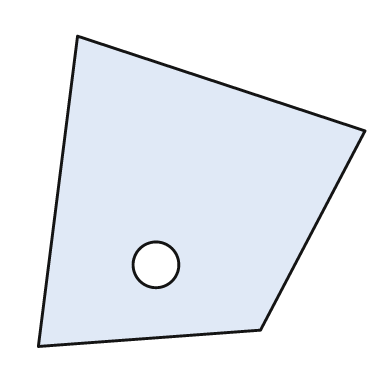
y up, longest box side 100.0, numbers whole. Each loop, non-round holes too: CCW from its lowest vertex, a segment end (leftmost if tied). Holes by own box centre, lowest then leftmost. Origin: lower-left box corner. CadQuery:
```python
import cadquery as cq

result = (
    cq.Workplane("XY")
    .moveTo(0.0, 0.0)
    .lineTo(68.0, 5.0)
    .lineTo(100.0, 66.0)
    .lineTo(12.0, 95.0)
    .close()
    .moveTo(36.0, 25.0)
    .circle(7.0)
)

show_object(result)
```